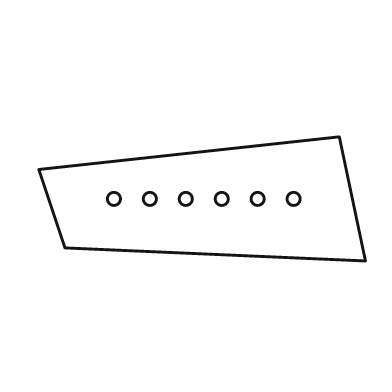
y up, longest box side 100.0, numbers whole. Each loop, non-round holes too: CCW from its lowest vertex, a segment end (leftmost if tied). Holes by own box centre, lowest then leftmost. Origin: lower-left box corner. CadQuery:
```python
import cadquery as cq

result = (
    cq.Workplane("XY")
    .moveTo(100.0, 0.0)
    .lineTo(92.0, 38.0)
    .lineTo(0.0, 28.0)
    .lineTo(8.0, 4.0)
    .close()
    .moveTo(23.0, 19.0)
    .circle(2.0)
    .moveTo(34.0, 19.0)
    .circle(2.0)
    .moveTo(45.0, 19.0)
    .circle(2.0)
    .moveTo(56.0, 19.0)
    .circle(2.0)
    .moveTo(67.0, 19.0)
    .circle(2.0)
    .moveTo(78.0, 19.0)
    .circle(2.0)
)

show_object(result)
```